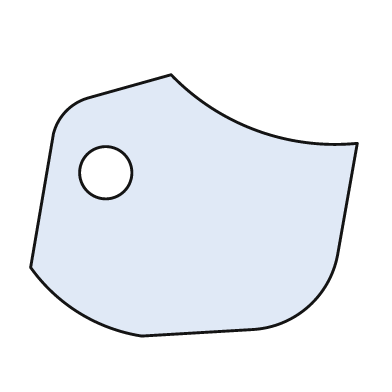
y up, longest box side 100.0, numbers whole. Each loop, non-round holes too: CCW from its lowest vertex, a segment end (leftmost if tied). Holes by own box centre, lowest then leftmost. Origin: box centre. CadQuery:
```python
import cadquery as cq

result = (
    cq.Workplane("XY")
    .moveTo(-16.0, -40.0)
    .lineTo(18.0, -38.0)
    .threePointArc((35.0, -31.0), (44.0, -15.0))
    .lineTo(50.0, 19.0)
    .threePointArc((19.0, 23.0), (-7.0, 40.0))
    .lineTo(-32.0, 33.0)
    .threePointArc((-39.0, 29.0), (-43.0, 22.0))
    .lineTo(-50.0, -19.0)
    .threePointArc((-35.0, -33.0), (-16.0, -40.0))
    .close()
    .moveTo(-27.0, 10.0)
    .circle(8.0)
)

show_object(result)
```